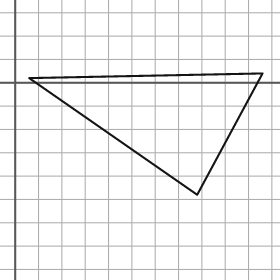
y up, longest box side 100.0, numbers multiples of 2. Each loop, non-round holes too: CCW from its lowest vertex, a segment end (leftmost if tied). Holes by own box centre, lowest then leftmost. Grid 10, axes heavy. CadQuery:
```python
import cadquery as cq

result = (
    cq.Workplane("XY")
    .moveTo(78.0, -48.0)
    .lineTo(106.0, 4.0)
    .lineTo(6.0, 2.0)
    .close()
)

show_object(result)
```